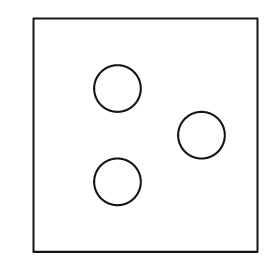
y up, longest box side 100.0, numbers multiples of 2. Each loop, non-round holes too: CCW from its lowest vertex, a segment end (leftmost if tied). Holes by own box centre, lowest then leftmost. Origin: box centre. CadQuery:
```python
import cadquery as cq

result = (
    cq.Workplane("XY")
    .moveTo(-48.0, -50.0)
    .lineTo(48.0, -50.0)
    .lineTo(48.0, 50.0)
    .lineTo(-48.0, 50.0)
    .close()
    .moveTo(-12.0, -20.0)
    .circle(10.0)
    .moveTo(24.0, 0.0)
    .circle(10.0)
    .moveTo(-12.0, 20.0)
    .circle(10.0)
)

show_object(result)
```